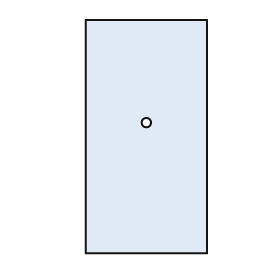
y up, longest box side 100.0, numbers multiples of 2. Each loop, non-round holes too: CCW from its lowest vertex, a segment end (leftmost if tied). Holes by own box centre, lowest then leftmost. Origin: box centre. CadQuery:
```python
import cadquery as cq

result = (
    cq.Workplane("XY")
    .moveTo(-26.0, -50.0)
    .lineTo(26.0, -50.0)
    .lineTo(26.0, 50.0)
    .lineTo(-26.0, 50.0)
    .close()
    .moveTo(0.0, 6.0)
    .circle(2.0)
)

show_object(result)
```